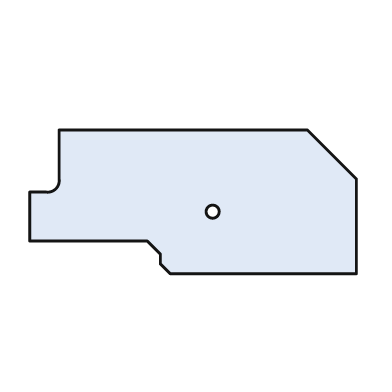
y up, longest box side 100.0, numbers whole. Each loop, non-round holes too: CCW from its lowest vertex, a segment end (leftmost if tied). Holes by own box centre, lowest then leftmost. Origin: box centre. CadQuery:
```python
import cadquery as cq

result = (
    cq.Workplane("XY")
    .moveTo(-7.0, -22.0)
    .lineTo(50.0, -22.0)
    .lineTo(50.0, 7.0)
    .lineTo(35.0, 22.0)
    .lineTo(-41.0, 22.0)
    .lineTo(-41.0, 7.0)
    .threePointArc((-42.0, 4.0), (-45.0, 3.0))
    .lineTo(-50.0, 3.0)
    .lineTo(-50.0, -12.0)
    .lineTo(-14.0, -12.0)
    .lineTo(-10.0, -16.0)
    .lineTo(-10.0, -19.0)
    .close()
    .moveTo(6.0, -3.0)
    .circle(2.0)
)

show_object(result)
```